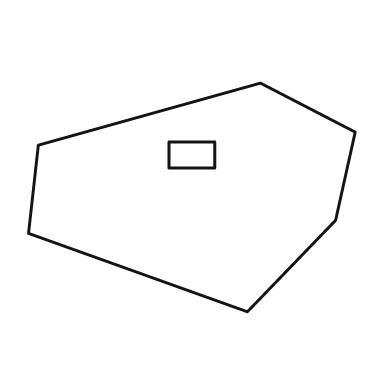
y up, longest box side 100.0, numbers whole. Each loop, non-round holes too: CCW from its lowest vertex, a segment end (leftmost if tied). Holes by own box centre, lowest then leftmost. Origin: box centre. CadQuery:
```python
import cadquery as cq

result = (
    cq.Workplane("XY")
    .moveTo(17.0, -35.0)
    .lineTo(44.0, -7.0)
    .lineTo(50.0, 20.0)
    .lineTo(21.0, 35.0)
    .lineTo(-47.0, 16.0)
    .lineTo(-50.0, -11.0)
    .close()
    .moveTo(-7.0, 9.0)
    .lineTo(7.0, 9.0)
    .lineTo(7.0, 17.0)
    .lineTo(-7.0, 17.0)
    .close()
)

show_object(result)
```